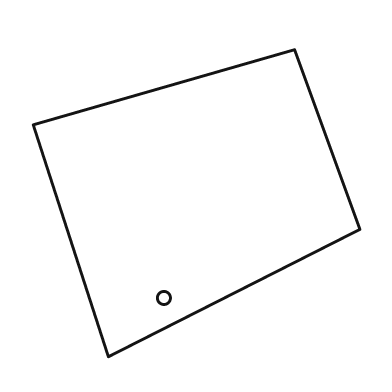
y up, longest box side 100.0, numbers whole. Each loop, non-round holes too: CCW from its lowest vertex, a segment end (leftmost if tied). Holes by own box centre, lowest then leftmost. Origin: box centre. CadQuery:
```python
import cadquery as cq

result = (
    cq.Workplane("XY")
    .moveTo(-27.0, -47.0)
    .lineTo(50.0, -8.0)
    .lineTo(30.0, 47.0)
    .lineTo(-50.0, 24.0)
    .close()
    .moveTo(-10.0, -29.0)
    .circle(2.0)
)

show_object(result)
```